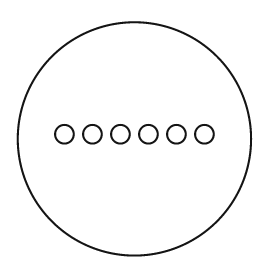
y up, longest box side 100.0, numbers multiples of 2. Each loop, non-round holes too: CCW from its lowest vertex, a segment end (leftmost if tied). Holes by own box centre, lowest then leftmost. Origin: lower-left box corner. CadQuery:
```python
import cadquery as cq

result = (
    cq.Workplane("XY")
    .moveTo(50.0, 50.0)
    .circle(50.0)
    .moveTo(20.0, 52.0)
    .circle(4.0)
    .moveTo(32.0, 52.0)
    .circle(4.0)
    .moveTo(44.0, 52.0)
    .circle(4.0)
    .moveTo(56.0, 52.0)
    .circle(4.0)
    .moveTo(68.0, 52.0)
    .circle(4.0)
    .moveTo(80.0, 52.0)
    .circle(4.0)
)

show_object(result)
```